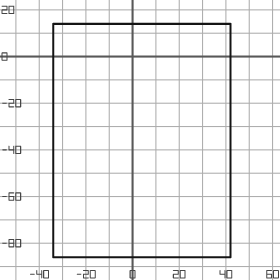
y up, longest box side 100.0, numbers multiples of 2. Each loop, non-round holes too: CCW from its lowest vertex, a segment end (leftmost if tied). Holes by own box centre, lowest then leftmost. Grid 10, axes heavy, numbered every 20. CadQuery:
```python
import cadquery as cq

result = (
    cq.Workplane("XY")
    .moveTo(-34.0, -86.0)
    .lineTo(42.0, -86.0)
    .lineTo(42.0, 14.0)
    .lineTo(-34.0, 14.0)
    .close()
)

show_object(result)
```